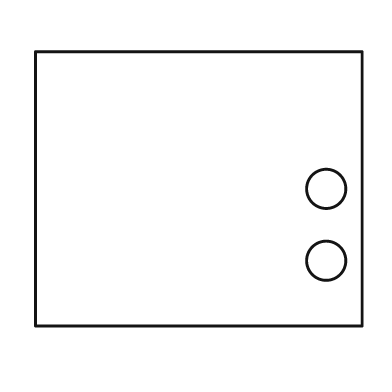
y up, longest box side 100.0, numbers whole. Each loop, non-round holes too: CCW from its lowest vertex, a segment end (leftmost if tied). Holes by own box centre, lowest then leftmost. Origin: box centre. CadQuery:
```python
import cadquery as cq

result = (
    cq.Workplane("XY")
    .moveTo(-50.0, -42.0)
    .lineTo(50.0, -42.0)
    .lineTo(50.0, 42.0)
    .lineTo(-50.0, 42.0)
    .close()
    .moveTo(39.0, -22.0)
    .circle(6.0)
    .moveTo(39.0, 0.0)
    .circle(6.0)
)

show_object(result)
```